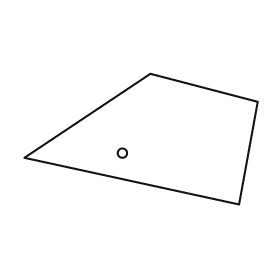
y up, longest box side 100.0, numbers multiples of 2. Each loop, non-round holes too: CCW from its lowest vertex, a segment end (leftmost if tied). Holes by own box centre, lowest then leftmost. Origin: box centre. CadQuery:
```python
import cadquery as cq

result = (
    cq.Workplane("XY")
    .moveTo(42.0, -28.0)
    .lineTo(50.0, 16.0)
    .lineTo(4.0, 28.0)
    .lineTo(-50.0, -8.0)
    .close()
    .moveTo(-8.0, -6.0)
    .circle(2.0)
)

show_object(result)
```